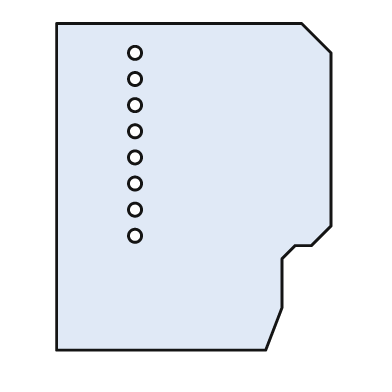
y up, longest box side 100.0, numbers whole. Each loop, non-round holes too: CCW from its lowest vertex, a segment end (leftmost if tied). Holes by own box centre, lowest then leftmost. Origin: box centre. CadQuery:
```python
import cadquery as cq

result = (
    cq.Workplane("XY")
    .moveTo(-42.0, -50.0)
    .lineTo(22.0, -50.0)
    .lineTo(27.0, -37.0)
    .lineTo(27.0, -22.0)
    .lineTo(31.0, -18.0)
    .lineTo(36.0, -18.0)
    .lineTo(42.0, -12.0)
    .lineTo(42.0, 41.0)
    .lineTo(33.0, 50.0)
    .lineTo(-42.0, 50.0)
    .close()
    .moveTo(-18.0, -15.0)
    .circle(2.0)
    .moveTo(-18.0, -7.0)
    .circle(2.0)
    .moveTo(-18.0, 1.0)
    .circle(2.0)
    .moveTo(-18.0, 9.0)
    .circle(2.0)
    .moveTo(-18.0, 17.0)
    .circle(2.0)
    .moveTo(-18.0, 25.0)
    .circle(2.0)
    .moveTo(-18.0, 33.0)
    .circle(2.0)
    .moveTo(-18.0, 41.0)
    .circle(2.0)
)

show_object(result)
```